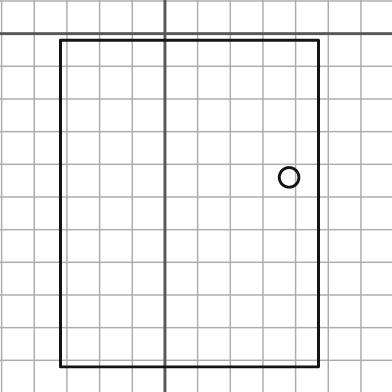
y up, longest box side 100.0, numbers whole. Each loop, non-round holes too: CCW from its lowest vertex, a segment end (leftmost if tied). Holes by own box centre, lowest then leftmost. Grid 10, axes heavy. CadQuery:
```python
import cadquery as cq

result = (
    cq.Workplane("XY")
    .moveTo(-32.0, -102.0)
    .lineTo(47.0, -102.0)
    .lineTo(47.0, -2.0)
    .lineTo(-32.0, -2.0)
    .close()
    .moveTo(38.0, -44.0)
    .circle(3.0)
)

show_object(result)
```